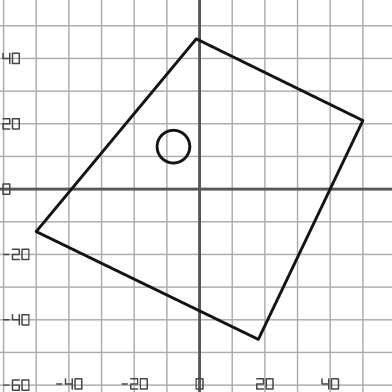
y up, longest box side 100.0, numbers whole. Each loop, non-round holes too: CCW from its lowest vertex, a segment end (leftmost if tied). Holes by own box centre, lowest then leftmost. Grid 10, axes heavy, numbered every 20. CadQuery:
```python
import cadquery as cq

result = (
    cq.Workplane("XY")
    .moveTo(18.0, -46.0)
    .lineTo(50.0, 21.0)
    .lineTo(-1.0, 46.0)
    .lineTo(-50.0, -13.0)
    .close()
    .moveTo(-8.0, 13.0)
    .circle(5.0)
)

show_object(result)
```